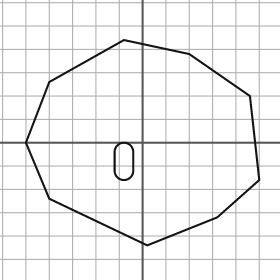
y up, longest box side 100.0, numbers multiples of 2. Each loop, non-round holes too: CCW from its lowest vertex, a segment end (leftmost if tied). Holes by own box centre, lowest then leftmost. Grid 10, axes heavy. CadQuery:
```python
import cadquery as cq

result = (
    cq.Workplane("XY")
    .moveTo(2.0, -44.0)
    .lineTo(32.0, -32.0)
    .lineTo(50.0, -16.0)
    .lineTo(46.0, 20.0)
    .lineTo(20.0, 38.0)
    .lineTo(-8.0, 44.0)
    .lineTo(-40.0, 26.0)
    .lineTo(-50.0, 0.0)
    .lineTo(-40.0, -24.0)
    .close()
    .moveTo(-12.0, -12.0)
    .threePointArc((-8.0, -16.0), (-4.0, -12.0))
    .lineTo(-4.0, -4.0)
    .threePointArc((-8.0, 0.0), (-12.0, -4.0))
    .close()
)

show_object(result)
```